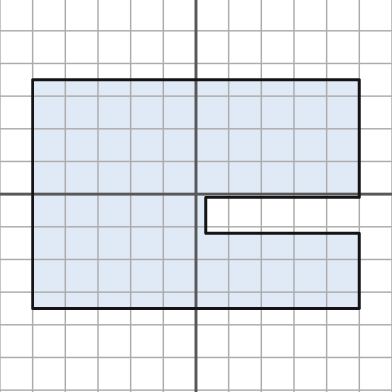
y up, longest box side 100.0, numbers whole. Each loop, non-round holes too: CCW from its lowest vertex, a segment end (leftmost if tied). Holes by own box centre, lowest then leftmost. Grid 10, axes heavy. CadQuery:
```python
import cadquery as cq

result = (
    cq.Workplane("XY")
    .moveTo(-50.0, -35.0)
    .lineTo(50.0, -35.0)
    .lineTo(50.0, -12.0)
    .lineTo(3.0, -12.0)
    .lineTo(3.0, -1.0)
    .lineTo(50.0, -1.0)
    .lineTo(50.0, 35.0)
    .lineTo(-50.0, 35.0)
    .close()
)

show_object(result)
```